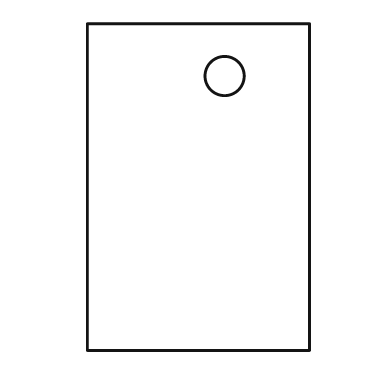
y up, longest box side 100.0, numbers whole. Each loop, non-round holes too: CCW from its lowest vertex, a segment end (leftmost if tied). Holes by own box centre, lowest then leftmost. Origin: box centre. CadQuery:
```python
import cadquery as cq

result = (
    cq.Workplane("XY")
    .moveTo(-34.0, -50.0)
    .lineTo(34.0, -50.0)
    .lineTo(34.0, 50.0)
    .lineTo(-34.0, 50.0)
    .close()
    .moveTo(8.0, 34.0)
    .circle(6.0)
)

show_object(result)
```